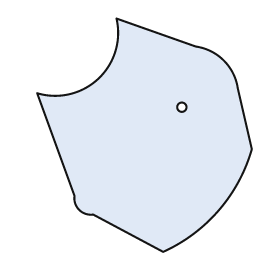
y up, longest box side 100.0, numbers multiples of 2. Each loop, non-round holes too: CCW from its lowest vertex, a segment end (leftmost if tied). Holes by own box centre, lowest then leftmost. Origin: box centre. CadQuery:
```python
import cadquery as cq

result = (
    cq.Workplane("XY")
    .moveTo(8.0, -50.0)
    .threePointArc((32.0, -32.0), (46.0, -6.0))
    .lineTo(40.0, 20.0)
    .threePointArc((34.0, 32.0), (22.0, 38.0))
    .lineTo(-12.0, 50.0)
    .threePointArc((-20.0, 24.0), (-46.0, 18.0))
    .lineTo(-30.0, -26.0)
    .threePointArc((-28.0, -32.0), (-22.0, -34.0))
    .close()
    .moveTo(16.0, 12.0)
    .circle(2.0)
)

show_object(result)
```